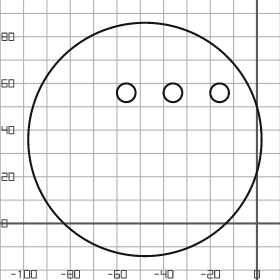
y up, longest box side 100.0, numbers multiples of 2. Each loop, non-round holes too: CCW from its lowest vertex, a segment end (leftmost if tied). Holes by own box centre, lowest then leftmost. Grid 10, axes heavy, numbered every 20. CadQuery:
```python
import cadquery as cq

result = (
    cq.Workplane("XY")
    .moveTo(-48.0, 36.0)
    .circle(50.0)
    .moveTo(-56.0, 56.0)
    .circle(4.0)
    .moveTo(-36.0, 56.0)
    .circle(4.0)
    .moveTo(-16.0, 56.0)
    .circle(4.0)
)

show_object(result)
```